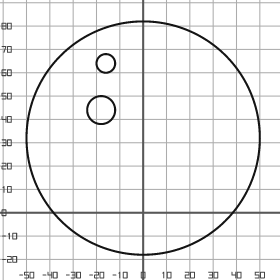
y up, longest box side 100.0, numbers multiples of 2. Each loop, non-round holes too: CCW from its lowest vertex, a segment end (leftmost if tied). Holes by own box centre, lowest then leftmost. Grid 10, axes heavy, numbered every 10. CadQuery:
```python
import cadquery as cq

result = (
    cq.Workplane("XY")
    .moveTo(0.0, 32.0)
    .circle(50.0)
    .moveTo(-18.0, 44.0)
    .circle(6.0)
    .moveTo(-16.0, 64.0)
    .circle(4.0)
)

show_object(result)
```